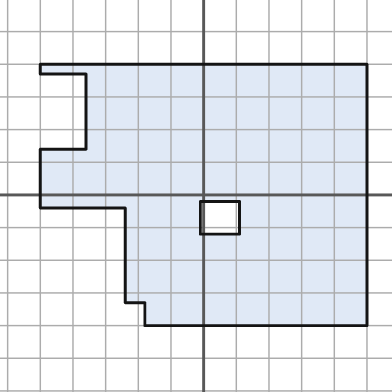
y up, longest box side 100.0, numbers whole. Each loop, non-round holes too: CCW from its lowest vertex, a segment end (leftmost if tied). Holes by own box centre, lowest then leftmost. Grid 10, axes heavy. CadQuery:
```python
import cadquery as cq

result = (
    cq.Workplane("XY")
    .moveTo(-18.0, -40.0)
    .lineTo(50.0, -40.0)
    .lineTo(50.0, 40.0)
    .lineTo(-50.0, 40.0)
    .lineTo(-50.0, 37.0)
    .lineTo(-36.0, 37.0)
    .lineTo(-36.0, 14.0)
    .lineTo(-50.0, 14.0)
    .lineTo(-50.0, -4.0)
    .lineTo(-24.0, -4.0)
    .lineTo(-24.0, -33.0)
    .lineTo(-18.0, -33.0)
    .close()
    .moveTo(-1.0, -12.0)
    .lineTo(11.0, -12.0)
    .lineTo(11.0, -2.0)
    .lineTo(-1.0, -2.0)
    .close()
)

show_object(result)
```